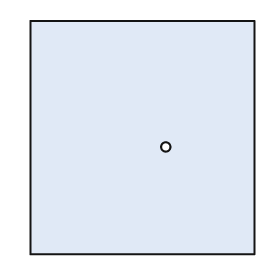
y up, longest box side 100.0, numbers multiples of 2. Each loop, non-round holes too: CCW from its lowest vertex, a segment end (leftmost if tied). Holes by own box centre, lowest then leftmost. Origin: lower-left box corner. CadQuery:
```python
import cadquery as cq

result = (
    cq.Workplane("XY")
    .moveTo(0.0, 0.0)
    .lineTo(96.0, 0.0)
    .lineTo(96.0, 100.0)
    .lineTo(0.0, 100.0)
    .close()
    .moveTo(58.0, 46.0)
    .circle(2.0)
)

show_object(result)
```